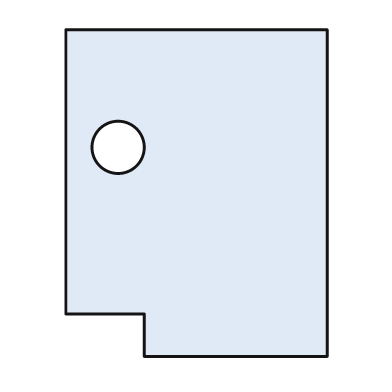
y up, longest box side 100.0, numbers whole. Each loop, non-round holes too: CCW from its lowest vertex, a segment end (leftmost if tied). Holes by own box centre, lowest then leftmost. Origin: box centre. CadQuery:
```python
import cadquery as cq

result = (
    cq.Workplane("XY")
    .moveTo(-16.0, -50.0)
    .lineTo(40.0, -50.0)
    .lineTo(40.0, 50.0)
    .lineTo(-40.0, 50.0)
    .lineTo(-40.0, -37.0)
    .lineTo(-16.0, -37.0)
    .close()
    .moveTo(-24.0, 14.0)
    .circle(8.0)
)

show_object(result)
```